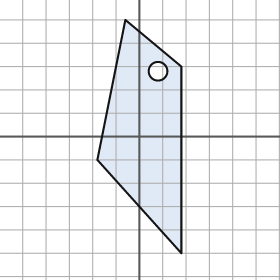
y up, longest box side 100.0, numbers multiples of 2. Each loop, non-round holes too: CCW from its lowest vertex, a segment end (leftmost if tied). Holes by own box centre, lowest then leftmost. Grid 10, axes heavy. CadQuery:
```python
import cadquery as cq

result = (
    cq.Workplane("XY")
    .moveTo(18.0, -50.0)
    .lineTo(18.0, 30.0)
    .lineTo(-6.0, 50.0)
    .lineTo(-18.0, -10.0)
    .close()
    .moveTo(8.0, 28.0)
    .circle(4.0)
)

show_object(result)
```